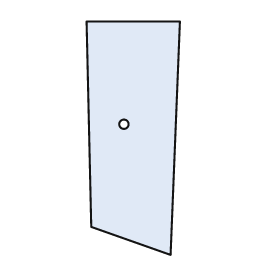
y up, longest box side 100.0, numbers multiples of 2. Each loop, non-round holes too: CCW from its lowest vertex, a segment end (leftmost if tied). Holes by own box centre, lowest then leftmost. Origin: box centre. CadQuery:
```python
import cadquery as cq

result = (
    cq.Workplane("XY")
    .moveTo(16.0, -50.0)
    .lineTo(20.0, 50.0)
    .lineTo(-20.0, 50.0)
    .lineTo(-18.0, -38.0)
    .close()
    .moveTo(-4.0, 6.0)
    .circle(2.0)
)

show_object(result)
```